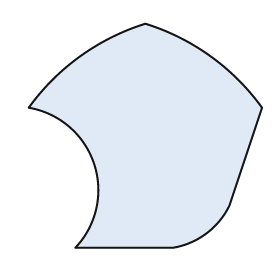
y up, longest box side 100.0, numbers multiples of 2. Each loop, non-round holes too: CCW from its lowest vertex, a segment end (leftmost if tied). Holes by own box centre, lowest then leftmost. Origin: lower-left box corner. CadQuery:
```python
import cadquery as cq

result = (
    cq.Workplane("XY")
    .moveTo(20.0, 0.0)
    .lineTo(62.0, 0.0)
    .threePointArc((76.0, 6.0), (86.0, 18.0))
    .lineTo(100.0, 60.0)
    .threePointArc((78.0, 82.0), (50.0, 96.0))
    .threePointArc((22.0, 82.0), (0.0, 60.0))
    .threePointArc((28.0, 36.0), (20.0, 0.0))
    .close()
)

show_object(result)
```